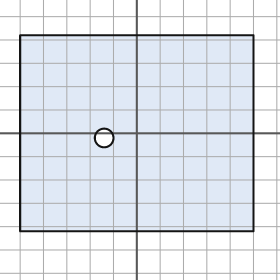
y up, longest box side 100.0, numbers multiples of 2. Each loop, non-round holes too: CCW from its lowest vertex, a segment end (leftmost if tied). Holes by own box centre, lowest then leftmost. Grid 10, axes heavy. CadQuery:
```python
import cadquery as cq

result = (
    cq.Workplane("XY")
    .moveTo(-50.0, -42.0)
    .lineTo(50.0, -42.0)
    .lineTo(50.0, 42.0)
    .lineTo(-50.0, 42.0)
    .close()
    .moveTo(-14.0, -2.0)
    .circle(4.0)
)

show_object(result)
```